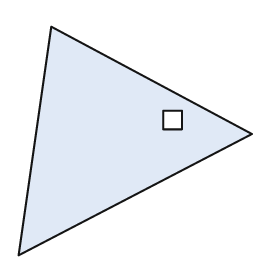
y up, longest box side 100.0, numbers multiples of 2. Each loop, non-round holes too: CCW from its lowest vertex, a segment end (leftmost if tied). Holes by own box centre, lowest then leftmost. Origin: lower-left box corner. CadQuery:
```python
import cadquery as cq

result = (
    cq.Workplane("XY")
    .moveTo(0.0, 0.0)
    .lineTo(100.0, 52.0)
    .lineTo(14.0, 98.0)
    .close()
    .moveTo(62.0, 54.0)
    .lineTo(70.0, 54.0)
    .lineTo(70.0, 62.0)
    .lineTo(62.0, 62.0)
    .close()
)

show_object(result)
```